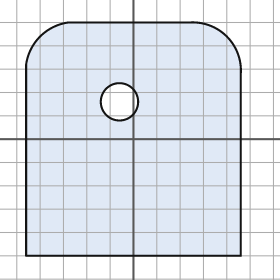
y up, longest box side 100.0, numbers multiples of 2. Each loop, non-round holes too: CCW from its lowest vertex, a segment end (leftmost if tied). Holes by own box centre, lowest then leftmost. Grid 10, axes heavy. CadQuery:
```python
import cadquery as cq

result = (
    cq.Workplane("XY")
    .moveTo(-46.0, -50.0)
    .lineTo(46.0, -50.0)
    .lineTo(46.0, 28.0)
    .threePointArc((40.0, 44.0), (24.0, 50.0))
    .lineTo(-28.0, 50.0)
    .threePointArc((-40.0, 44.0), (-46.0, 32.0))
    .close()
    .moveTo(-6.0, 16.0)
    .circle(8.0)
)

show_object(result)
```